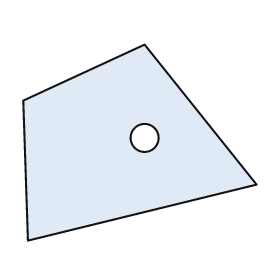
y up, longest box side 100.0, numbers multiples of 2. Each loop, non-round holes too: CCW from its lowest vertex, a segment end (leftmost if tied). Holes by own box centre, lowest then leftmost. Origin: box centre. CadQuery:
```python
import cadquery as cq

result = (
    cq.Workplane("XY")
    .moveTo(-48.0, -42.0)
    .lineTo(50.0, -18.0)
    .lineTo(2.0, 42.0)
    .lineTo(-50.0, 18.0)
    .close()
    .moveTo(2.0, 2.0)
    .circle(6.0)
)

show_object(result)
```